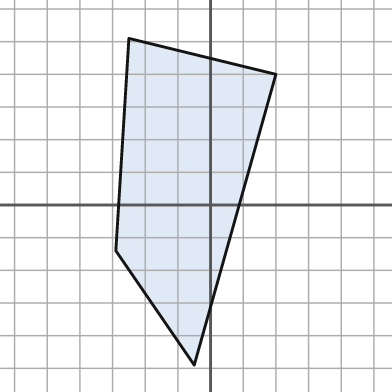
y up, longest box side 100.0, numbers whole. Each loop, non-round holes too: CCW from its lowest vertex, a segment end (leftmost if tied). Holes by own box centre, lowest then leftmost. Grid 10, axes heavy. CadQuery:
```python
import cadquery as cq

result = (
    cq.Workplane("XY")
    .moveTo(-5.0, -49.0)
    .lineTo(20.0, 40.0)
    .lineTo(-25.0, 51.0)
    .lineTo(-29.0, -14.0)
    .close()
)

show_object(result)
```